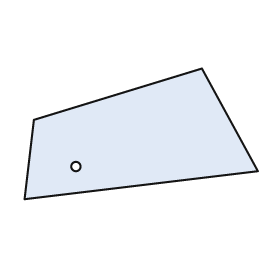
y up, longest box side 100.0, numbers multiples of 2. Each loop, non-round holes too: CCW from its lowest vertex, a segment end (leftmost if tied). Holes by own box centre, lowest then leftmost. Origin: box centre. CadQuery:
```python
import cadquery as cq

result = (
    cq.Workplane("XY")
    .moveTo(-50.0, -28.0)
    .lineTo(50.0, -16.0)
    .lineTo(26.0, 28.0)
    .lineTo(-46.0, 6.0)
    .close()
    .moveTo(-28.0, -14.0)
    .circle(2.0)
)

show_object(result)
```